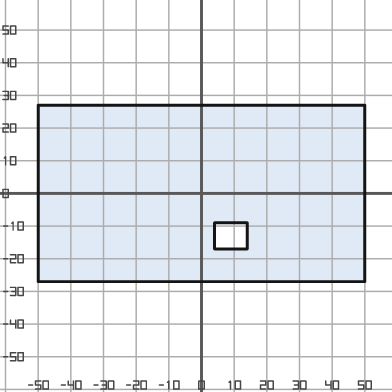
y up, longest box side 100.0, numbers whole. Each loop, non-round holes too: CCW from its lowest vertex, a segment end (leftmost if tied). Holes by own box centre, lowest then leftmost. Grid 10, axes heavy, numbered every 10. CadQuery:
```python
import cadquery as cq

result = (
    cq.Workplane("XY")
    .moveTo(-50.0, -27.0)
    .lineTo(50.0, -27.0)
    .lineTo(50.0, 27.0)
    .lineTo(-50.0, 27.0)
    .close()
    .moveTo(4.0, -17.0)
    .lineTo(14.0, -17.0)
    .lineTo(14.0, -9.0)
    .lineTo(4.0, -9.0)
    .close()
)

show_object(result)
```